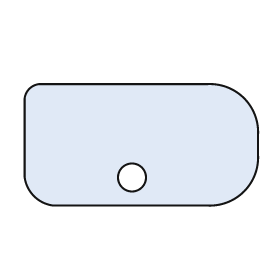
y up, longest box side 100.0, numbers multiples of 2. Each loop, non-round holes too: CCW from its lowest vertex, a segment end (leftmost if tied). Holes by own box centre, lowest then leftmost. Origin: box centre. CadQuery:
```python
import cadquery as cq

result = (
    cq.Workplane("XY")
    .moveTo(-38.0, -26.0)
    .lineTo(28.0, -26.0)
    .threePointArc((44.0, -20.0), (50.0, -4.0))
    .lineTo(50.0, 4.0)
    .threePointArc((44.0, 20.0), (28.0, 26.0))
    .lineTo(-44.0, 26.0)
    .threePointArc((-48.0, 24.0), (-50.0, 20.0))
    .lineTo(-50.0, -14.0)
    .threePointArc((-46.0, -22.0), (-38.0, -26.0))
    .close()
    .moveTo(-4.0, -14.0)
    .circle(6.0)
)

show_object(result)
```